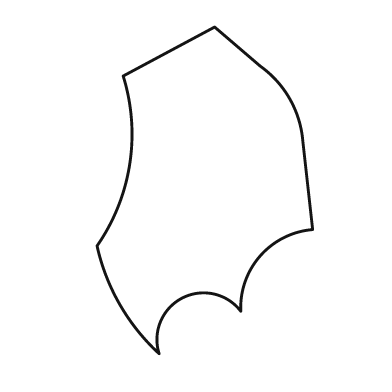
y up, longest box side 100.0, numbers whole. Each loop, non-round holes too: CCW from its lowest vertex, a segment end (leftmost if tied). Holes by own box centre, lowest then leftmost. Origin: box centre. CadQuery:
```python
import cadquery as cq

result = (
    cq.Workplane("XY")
    .moveTo(-14.0, -50.0)
    .threePointArc((-7.0, -33.0), (11.0, -37.0))
    .threePointArc((17.0, -20.0), (33.0, -12.0))
    .lineTo(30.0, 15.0)
    .threePointArc((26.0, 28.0), (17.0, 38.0))
    .lineTo(3.0, 50.0)
    .lineTo(-25.0, 35.0)
    .threePointArc((-23.0, 8.0), (-33.0, -17.0))
    .threePointArc((-26.0, -35.0), (-14.0, -50.0))
    .close()
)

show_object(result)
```